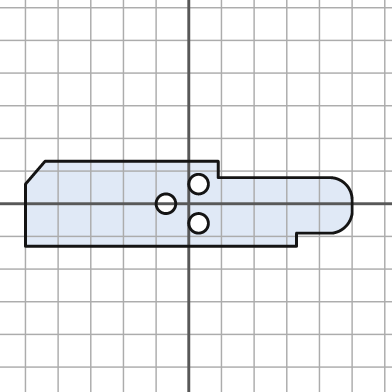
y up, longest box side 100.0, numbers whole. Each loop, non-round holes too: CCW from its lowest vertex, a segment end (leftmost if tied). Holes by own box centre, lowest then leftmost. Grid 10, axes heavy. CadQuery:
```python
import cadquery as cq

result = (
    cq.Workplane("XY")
    .moveTo(-50.0, -13.0)
    .lineTo(33.0, -13.0)
    .lineTo(33.0, -9.0)
    .lineTo(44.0, -9.0)
    .threePointArc((48.0, -7.0), (50.0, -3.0))
    .lineTo(50.0, 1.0)
    .threePointArc((48.0, 6.0), (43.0, 8.0))
    .lineTo(9.0, 8.0)
    .lineTo(9.0, 13.0)
    .lineTo(-44.0, 13.0)
    .lineTo(-50.0, 6.0)
    .close()
    .moveTo(3.0, -6.0)
    .circle(3.0)
    .moveTo(-7.0, 0.0)
    .circle(3.0)
    .moveTo(3.0, 6.0)
    .circle(3.0)
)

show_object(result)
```